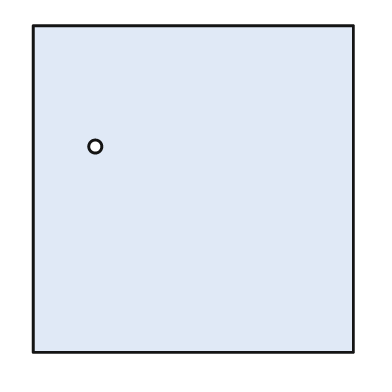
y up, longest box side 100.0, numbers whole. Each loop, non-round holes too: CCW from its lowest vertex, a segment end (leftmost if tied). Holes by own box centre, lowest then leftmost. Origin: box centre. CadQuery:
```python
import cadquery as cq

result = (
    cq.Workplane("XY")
    .moveTo(-49.0, -50.0)
    .lineTo(49.0, -50.0)
    .lineTo(49.0, 50.0)
    .lineTo(-49.0, 50.0)
    .close()
    .moveTo(-30.0, 13.0)
    .circle(2.0)
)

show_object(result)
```